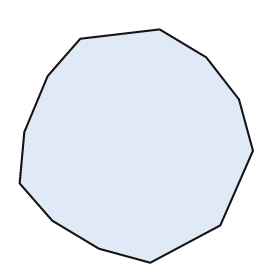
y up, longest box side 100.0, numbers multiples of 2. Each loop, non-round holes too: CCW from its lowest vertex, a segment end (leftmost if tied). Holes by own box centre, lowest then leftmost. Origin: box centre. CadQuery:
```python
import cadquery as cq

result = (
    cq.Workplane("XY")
    .moveTo(6.0, -50.0)
    .lineTo(36.0, -34.0)
    .lineTo(50.0, -2.0)
    .lineTo(44.0, 20.0)
    .lineTo(30.0, 38.0)
    .lineTo(10.0, 50.0)
    .lineTo(-24.0, 46.0)
    .lineTo(-38.0, 30.0)
    .lineTo(-48.0, 6.0)
    .lineTo(-50.0, -16.0)
    .lineTo(-36.0, -32.0)
    .lineTo(-16.0, -44.0)
    .close()
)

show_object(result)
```